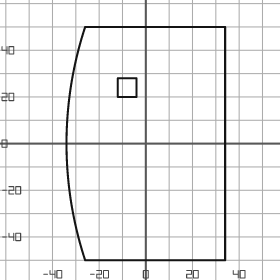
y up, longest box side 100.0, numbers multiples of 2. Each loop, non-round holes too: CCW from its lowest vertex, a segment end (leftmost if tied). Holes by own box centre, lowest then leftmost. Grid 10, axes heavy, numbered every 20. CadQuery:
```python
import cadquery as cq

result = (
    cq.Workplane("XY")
    .moveTo(-26.0, -50.0)
    .lineTo(34.0, -50.0)
    .lineTo(34.0, 50.0)
    .lineTo(-26.0, 50.0)
    .threePointArc((-34.0, 0.0), (-26.0, -50.0))
    .close()
    .moveTo(-12.0, 20.0)
    .lineTo(-4.0, 20.0)
    .lineTo(-4.0, 28.0)
    .lineTo(-12.0, 28.0)
    .close()
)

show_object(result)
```